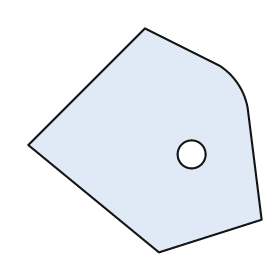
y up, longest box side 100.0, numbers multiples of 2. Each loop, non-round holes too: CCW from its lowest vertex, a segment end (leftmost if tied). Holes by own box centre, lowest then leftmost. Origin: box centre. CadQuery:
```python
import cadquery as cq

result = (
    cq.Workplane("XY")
    .moveTo(6.0, -48.0)
    .lineTo(50.0, -34.0)
    .lineTo(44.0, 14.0)
    .threePointArc((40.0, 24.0), (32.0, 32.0))
    .lineTo(0.0, 48.0)
    .lineTo(-50.0, -2.0)
    .close()
    .moveTo(20.0, -6.0)
    .circle(6.0)
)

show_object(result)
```